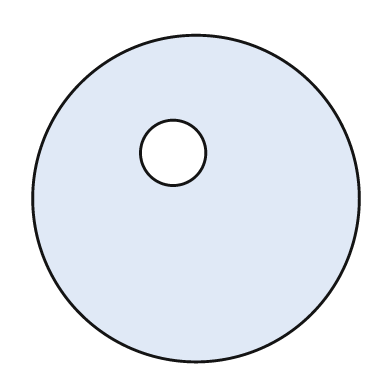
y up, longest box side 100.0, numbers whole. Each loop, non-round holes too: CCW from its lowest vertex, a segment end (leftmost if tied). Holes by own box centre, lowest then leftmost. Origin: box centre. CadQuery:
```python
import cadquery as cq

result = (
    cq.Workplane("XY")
    .moveTo(0.0, 0.0)
    .circle(50.0)
    .moveTo(-7.0, 14.0)
    .circle(10.0)
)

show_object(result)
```